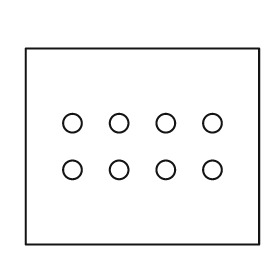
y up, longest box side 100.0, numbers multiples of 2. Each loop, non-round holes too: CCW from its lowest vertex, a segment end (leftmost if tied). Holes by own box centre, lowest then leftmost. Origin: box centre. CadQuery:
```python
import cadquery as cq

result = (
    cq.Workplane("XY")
    .moveTo(-50.0, -42.0)
    .lineTo(50.0, -42.0)
    .lineTo(50.0, 42.0)
    .lineTo(-50.0, 42.0)
    .close()
    .moveTo(-30.0, -10.0)
    .circle(4.0)
    .moveTo(-10.0, -10.0)
    .circle(4.0)
    .moveTo(10.0, -10.0)
    .circle(4.0)
    .moveTo(30.0, -10.0)
    .circle(4.0)
    .moveTo(-30.0, 10.0)
    .circle(4.0)
    .moveTo(-10.0, 10.0)
    .circle(4.0)
    .moveTo(10.0, 10.0)
    .circle(4.0)
    .moveTo(30.0, 10.0)
    .circle(4.0)
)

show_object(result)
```